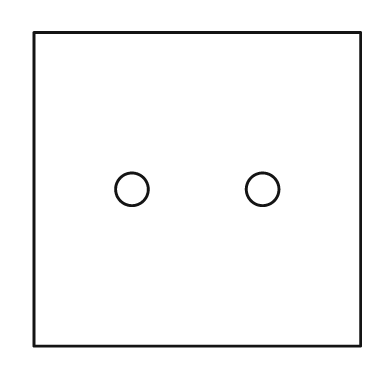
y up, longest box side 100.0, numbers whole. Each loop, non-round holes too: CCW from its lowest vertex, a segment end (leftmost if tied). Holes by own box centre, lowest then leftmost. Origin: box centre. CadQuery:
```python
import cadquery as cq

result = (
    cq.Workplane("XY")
    .moveTo(-50.0, -48.0)
    .lineTo(50.0, -48.0)
    .lineTo(50.0, 48.0)
    .lineTo(-50.0, 48.0)
    .close()
    .moveTo(-20.0, 0.0)
    .circle(5.0)
    .moveTo(20.0, 0.0)
    .circle(5.0)
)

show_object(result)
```